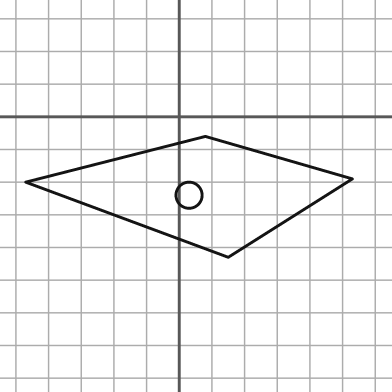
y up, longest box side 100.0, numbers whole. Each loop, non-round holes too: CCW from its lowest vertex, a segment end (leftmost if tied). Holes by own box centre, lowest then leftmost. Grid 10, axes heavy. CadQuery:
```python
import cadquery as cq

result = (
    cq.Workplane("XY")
    .moveTo(15.0, -43.0)
    .lineTo(53.0, -19.0)
    .lineTo(8.0, -6.0)
    .lineTo(-47.0, -20.0)
    .close()
    .moveTo(3.0, -24.0)
    .circle(4.0)
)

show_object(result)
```